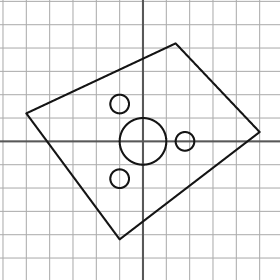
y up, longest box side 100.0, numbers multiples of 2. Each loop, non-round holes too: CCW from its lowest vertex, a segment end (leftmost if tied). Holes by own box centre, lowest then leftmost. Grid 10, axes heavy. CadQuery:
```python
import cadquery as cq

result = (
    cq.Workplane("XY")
    .moveTo(-10.0, -42.0)
    .lineTo(50.0, 4.0)
    .lineTo(14.0, 42.0)
    .lineTo(-50.0, 12.0)
    .close()
    .moveTo(-10.0, -16.0)
    .circle(4.0)
    .moveTo(0.0, 0.0)
    .circle(10.0)
    .moveTo(18.0, 0.0)
    .circle(4.0)
    .moveTo(-10.0, 16.0)
    .circle(4.0)
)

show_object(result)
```